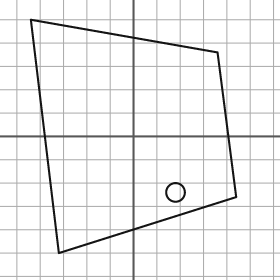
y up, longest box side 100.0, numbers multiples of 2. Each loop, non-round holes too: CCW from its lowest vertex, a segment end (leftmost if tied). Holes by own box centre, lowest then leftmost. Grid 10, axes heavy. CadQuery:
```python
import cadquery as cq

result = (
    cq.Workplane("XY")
    .moveTo(-32.0, -50.0)
    .lineTo(44.0, -26.0)
    .lineTo(36.0, 36.0)
    .lineTo(-44.0, 50.0)
    .close()
    .moveTo(18.0, -24.0)
    .circle(4.0)
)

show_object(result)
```